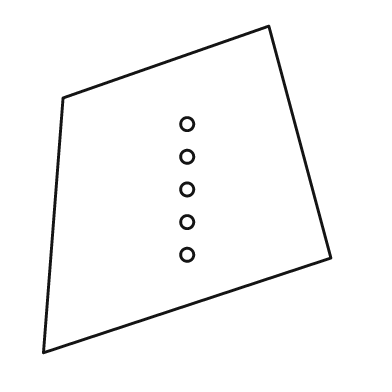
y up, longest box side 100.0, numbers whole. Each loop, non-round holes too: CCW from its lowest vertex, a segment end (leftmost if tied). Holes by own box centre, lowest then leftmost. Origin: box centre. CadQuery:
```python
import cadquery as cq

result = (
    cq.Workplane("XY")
    .moveTo(-44.0, -50.0)
    .lineTo(44.0, -21.0)
    .lineTo(25.0, 50.0)
    .lineTo(-38.0, 28.0)
    .close()
    .moveTo(0.0, -20.0)
    .circle(2.0)
    .moveTo(0.0, -10.0)
    .circle(2.0)
    .moveTo(0.0, 0.0)
    .circle(2.0)
    .moveTo(0.0, 10.0)
    .circle(2.0)
    .moveTo(0.0, 20.0)
    .circle(2.0)
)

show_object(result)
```